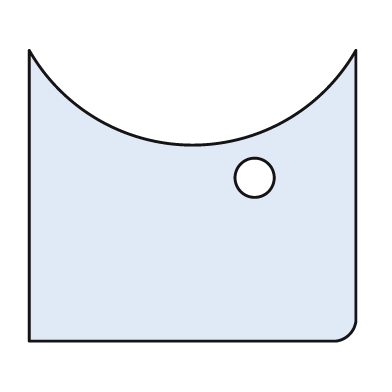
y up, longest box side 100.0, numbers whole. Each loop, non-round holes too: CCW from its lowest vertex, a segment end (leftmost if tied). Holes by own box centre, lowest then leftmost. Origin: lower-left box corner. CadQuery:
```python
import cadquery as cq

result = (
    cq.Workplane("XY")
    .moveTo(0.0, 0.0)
    .lineTo(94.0, 0.0)
    .threePointArc((98.0, 2.0), (100.0, 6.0))
    .lineTo(100.0, 89.0)
    .threePointArc((50.0, 60.0), (0.0, 89.0))
    .close()
    .moveTo(69.0, 50.0)
    .circle(6.0)
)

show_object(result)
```